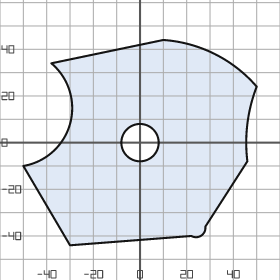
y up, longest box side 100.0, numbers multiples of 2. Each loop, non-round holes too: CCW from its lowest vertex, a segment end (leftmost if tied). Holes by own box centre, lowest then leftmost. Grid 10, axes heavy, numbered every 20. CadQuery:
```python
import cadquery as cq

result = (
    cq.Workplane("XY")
    .moveTo(-30.0, -44.0)
    .lineTo(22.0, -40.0)
    .threePointArc((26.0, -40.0), (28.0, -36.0))
    .lineTo(46.0, -8.0)
    .threePointArc((46.0, 8.0), (50.0, 24.0))
    .threePointArc((32.0, 38.0), (10.0, 44.0))
    .lineTo(-38.0, 34.0)
    .threePointArc((-30.0, 8.0), (-50.0, -10.0))
    .close()
    .moveTo(0.0, 0.0)
    .circle(8.0)
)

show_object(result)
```